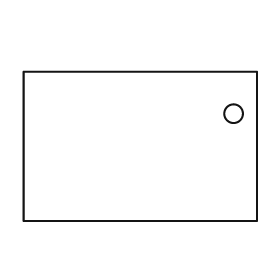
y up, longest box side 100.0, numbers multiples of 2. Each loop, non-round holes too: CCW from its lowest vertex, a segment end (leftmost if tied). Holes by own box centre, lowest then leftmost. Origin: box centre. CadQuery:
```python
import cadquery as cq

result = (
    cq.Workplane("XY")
    .moveTo(-50.0, -32.0)
    .lineTo(50.0, -32.0)
    .lineTo(50.0, 32.0)
    .lineTo(-50.0, 32.0)
    .close()
    .moveTo(40.0, 14.0)
    .circle(4.0)
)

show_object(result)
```